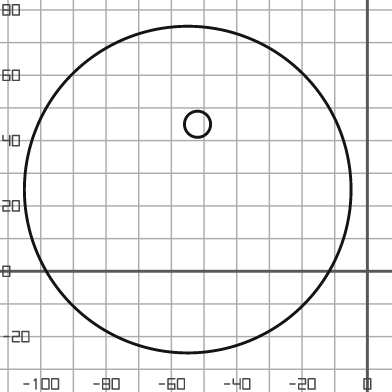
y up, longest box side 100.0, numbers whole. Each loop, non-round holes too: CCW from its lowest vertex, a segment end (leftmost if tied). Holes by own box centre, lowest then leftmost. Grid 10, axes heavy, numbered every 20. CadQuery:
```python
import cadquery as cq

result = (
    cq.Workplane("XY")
    .moveTo(-55.0, 25.0)
    .circle(50.0)
    .moveTo(-52.0, 45.0)
    .circle(4.0)
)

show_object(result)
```